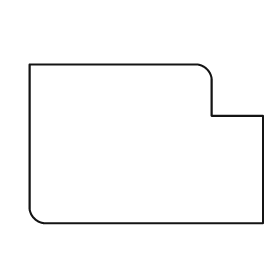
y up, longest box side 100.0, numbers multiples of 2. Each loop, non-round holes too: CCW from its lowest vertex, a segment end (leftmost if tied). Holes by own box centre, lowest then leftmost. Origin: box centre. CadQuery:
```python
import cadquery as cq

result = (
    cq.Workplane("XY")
    .moveTo(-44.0, -34.0)
    .lineTo(50.0, -34.0)
    .lineTo(50.0, 12.0)
    .lineTo(28.0, 12.0)
    .lineTo(28.0, 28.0)
    .threePointArc((26.0, 32.0), (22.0, 34.0))
    .lineTo(-50.0, 34.0)
    .lineTo(-50.0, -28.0)
    .threePointArc((-48.0, -32.0), (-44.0, -34.0))
    .close()
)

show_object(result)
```